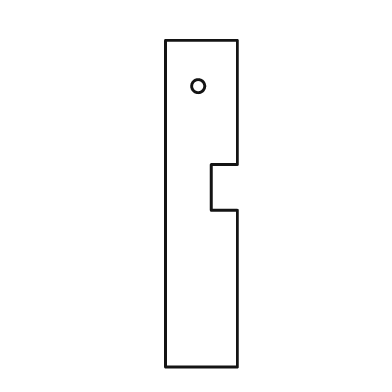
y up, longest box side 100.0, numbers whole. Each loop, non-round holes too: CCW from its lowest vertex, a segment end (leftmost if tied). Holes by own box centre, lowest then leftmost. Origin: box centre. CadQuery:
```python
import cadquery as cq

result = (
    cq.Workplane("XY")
    .moveTo(-11.0, -50.0)
    .lineTo(11.0, -50.0)
    .lineTo(11.0, -2.0)
    .lineTo(3.0, -2.0)
    .lineTo(3.0, 12.0)
    .lineTo(11.0, 12.0)
    .lineTo(11.0, 50.0)
    .lineTo(-11.0, 50.0)
    .close()
    .moveTo(-1.0, 36.0)
    .circle(2.0)
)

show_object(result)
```